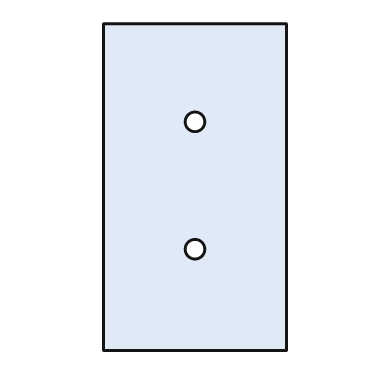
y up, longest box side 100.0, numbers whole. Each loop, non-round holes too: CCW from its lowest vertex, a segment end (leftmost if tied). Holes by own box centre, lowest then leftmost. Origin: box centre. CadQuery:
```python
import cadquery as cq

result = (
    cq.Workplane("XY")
    .moveTo(-28.0, -50.0)
    .lineTo(28.0, -50.0)
    .lineTo(28.0, 50.0)
    .lineTo(-28.0, 50.0)
    .close()
    .moveTo(0.0, -19.0)
    .circle(3.0)
    .moveTo(0.0, 20.0)
    .circle(3.0)
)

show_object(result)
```